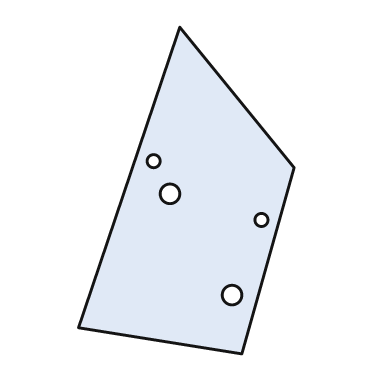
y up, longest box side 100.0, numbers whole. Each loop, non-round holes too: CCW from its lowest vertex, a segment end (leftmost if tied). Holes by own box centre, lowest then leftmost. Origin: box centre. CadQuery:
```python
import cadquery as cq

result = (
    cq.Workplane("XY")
    .moveTo(17.0, -50.0)
    .lineTo(33.0, 7.0)
    .lineTo(-2.0, 50.0)
    .lineTo(-33.0, -42.0)
    .close()
    .moveTo(14.0, -32.0)
    .circle(3.0)
    .moveTo(23.0, -9.0)
    .circle(2.0)
    .moveTo(-5.0, -1.0)
    .circle(3.0)
    .moveTo(-10.0, 9.0)
    .circle(2.0)
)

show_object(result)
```